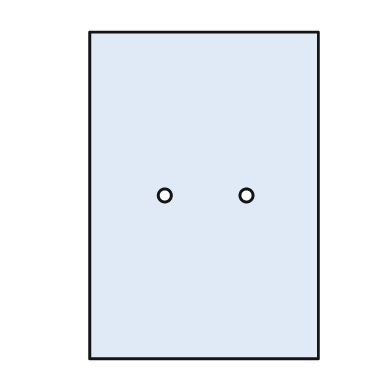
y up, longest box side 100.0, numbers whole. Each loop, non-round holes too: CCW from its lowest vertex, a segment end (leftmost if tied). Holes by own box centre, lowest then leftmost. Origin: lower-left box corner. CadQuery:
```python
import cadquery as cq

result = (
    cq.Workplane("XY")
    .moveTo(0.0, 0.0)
    .lineTo(70.0, 0.0)
    .lineTo(70.0, 100.0)
    .lineTo(0.0, 100.0)
    .close()
    .moveTo(23.0, 50.0)
    .circle(2.0)
    .moveTo(48.0, 50.0)
    .circle(2.0)
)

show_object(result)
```